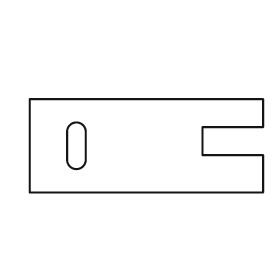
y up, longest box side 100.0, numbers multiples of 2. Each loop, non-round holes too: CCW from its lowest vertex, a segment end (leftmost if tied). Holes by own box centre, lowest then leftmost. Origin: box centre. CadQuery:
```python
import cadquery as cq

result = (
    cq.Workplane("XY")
    .moveTo(-50.0, -20.0)
    .lineTo(50.0, -20.0)
    .lineTo(50.0, -4.0)
    .lineTo(24.0, -4.0)
    .lineTo(24.0, 8.0)
    .lineTo(50.0, 8.0)
    .lineTo(50.0, 20.0)
    .lineTo(-50.0, 20.0)
    .close()
    .moveTo(-34.0, -6.0)
    .threePointArc((-30.0, -10.0), (-26.0, -6.0))
    .lineTo(-26.0, 6.0)
    .threePointArc((-30.0, 10.0), (-34.0, 6.0))
    .close()
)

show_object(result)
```